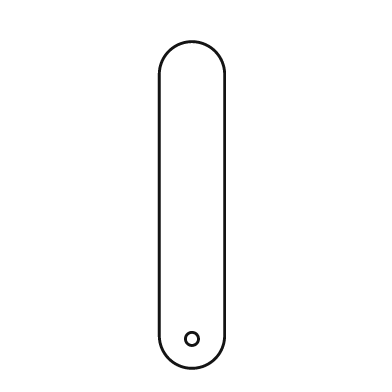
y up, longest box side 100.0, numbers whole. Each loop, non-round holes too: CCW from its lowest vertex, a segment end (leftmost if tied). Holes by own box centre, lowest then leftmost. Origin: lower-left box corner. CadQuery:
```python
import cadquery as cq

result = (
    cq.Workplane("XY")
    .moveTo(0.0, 10.0)
    .threePointArc((10.0, 0.0), (20.0, 10.0))
    .lineTo(20.0, 90.0)
    .threePointArc((10.0, 100.0), (0.0, 90.0))
    .close()
    .moveTo(10.0, 9.0)
    .circle(2.0)
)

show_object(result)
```